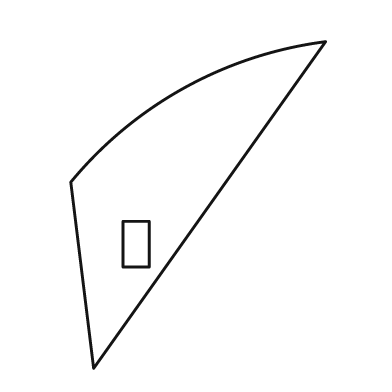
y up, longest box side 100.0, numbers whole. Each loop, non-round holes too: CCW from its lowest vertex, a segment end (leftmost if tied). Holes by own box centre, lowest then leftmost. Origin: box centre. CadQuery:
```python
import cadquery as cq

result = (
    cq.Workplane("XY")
    .moveTo(-32.0, -50.0)
    .lineTo(39.0, 50.0)
    .threePointArc((-4.0, 36.0), (-39.0, 7.0))
    .close()
    .moveTo(-23.0, -19.0)
    .lineTo(-15.0, -19.0)
    .lineTo(-15.0, -5.0)
    .lineTo(-23.0, -5.0)
    .close()
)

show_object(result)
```